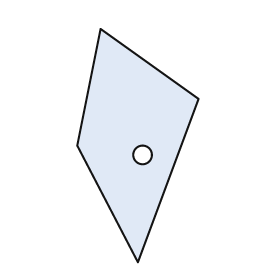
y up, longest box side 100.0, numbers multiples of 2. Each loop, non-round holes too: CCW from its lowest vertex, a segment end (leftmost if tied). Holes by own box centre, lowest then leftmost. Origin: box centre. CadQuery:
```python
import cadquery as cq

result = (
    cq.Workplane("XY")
    .moveTo(0.0, -50.0)
    .lineTo(26.0, 20.0)
    .lineTo(-16.0, 50.0)
    .lineTo(-26.0, 0.0)
    .close()
    .moveTo(2.0, -4.0)
    .circle(4.0)
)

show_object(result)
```